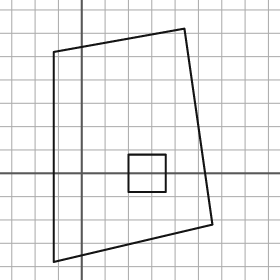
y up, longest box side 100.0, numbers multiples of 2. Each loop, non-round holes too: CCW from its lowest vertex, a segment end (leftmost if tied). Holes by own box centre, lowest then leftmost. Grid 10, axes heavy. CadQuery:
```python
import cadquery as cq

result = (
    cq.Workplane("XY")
    .moveTo(-12.0, -38.0)
    .lineTo(56.0, -22.0)
    .lineTo(44.0, 62.0)
    .lineTo(-12.0, 52.0)
    .close()
    .moveTo(20.0, -8.0)
    .lineTo(36.0, -8.0)
    .lineTo(36.0, 8.0)
    .lineTo(20.0, 8.0)
    .close()
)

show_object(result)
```